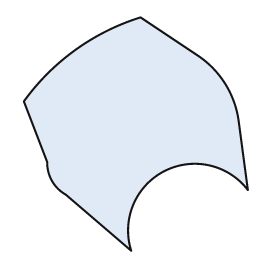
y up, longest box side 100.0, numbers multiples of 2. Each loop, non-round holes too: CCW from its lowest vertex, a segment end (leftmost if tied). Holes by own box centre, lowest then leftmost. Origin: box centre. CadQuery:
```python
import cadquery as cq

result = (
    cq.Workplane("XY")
    .moveTo(-2.0, -50.0)
    .threePointArc((12.0, -16.0), (48.0, -24.0))
    .lineTo(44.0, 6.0)
    .threePointArc((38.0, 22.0), (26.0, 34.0))
    .lineTo(2.0, 50.0)
    .threePointArc((-26.0, 36.0), (-48.0, 14.0))
    .lineTo(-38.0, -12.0)
    .threePointArc((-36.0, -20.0), (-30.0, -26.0))
    .close()
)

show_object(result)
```